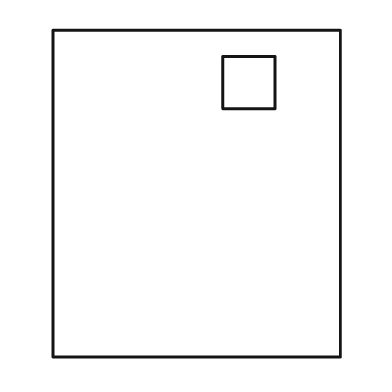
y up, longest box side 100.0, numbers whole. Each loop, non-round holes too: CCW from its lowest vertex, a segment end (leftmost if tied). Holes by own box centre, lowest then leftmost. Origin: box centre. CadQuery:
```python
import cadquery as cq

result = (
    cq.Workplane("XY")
    .moveTo(-44.0, -50.0)
    .lineTo(44.0, -50.0)
    .lineTo(44.0, 50.0)
    .lineTo(-44.0, 50.0)
    .close()
    .moveTo(8.0, 26.0)
    .lineTo(24.0, 26.0)
    .lineTo(24.0, 42.0)
    .lineTo(8.0, 42.0)
    .close()
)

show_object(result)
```